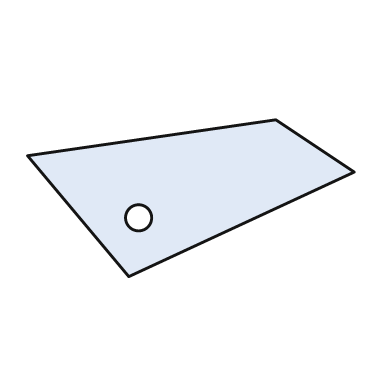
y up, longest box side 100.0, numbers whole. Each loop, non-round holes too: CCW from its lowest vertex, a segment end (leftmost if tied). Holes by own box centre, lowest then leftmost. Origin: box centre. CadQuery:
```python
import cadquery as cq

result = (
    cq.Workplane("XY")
    .moveTo(-19.0, -24.0)
    .lineTo(50.0, 8.0)
    .lineTo(26.0, 24.0)
    .lineTo(-50.0, 13.0)
    .close()
    .moveTo(-16.0, -6.0)
    .circle(4.0)
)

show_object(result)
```